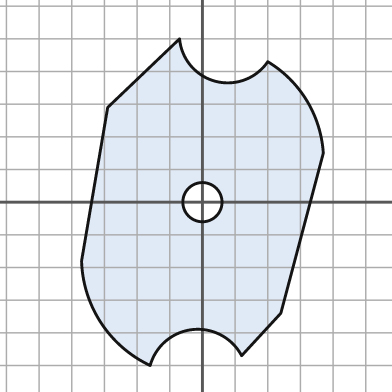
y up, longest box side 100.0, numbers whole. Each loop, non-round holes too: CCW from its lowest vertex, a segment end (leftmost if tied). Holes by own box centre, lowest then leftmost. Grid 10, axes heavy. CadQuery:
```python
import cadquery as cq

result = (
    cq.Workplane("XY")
    .moveTo(-16.0, -50.0)
    .threePointArc((-3.0, -39.0), (12.0, -47.0))
    .lineTo(24.0, -34.0)
    .lineTo(37.0, 15.0)
    .threePointArc((32.0, 31.0), (20.0, 43.0))
    .threePointArc((4.0, 37.0), (-7.0, 50.0))
    .lineTo(-29.0, 29.0)
    .lineTo(-37.0, -18.0)
    .threePointArc((-31.0, -37.0), (-16.0, -50.0))
    .close()
    .moveTo(0.0, 0.0)
    .circle(6.0)
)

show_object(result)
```